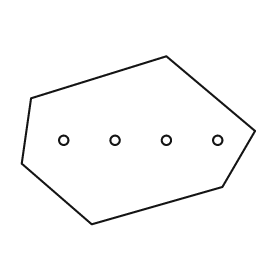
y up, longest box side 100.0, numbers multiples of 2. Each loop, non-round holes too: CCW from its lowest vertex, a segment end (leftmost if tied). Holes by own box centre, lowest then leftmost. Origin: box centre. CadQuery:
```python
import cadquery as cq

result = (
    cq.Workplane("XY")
    .moveTo(-20.0, -36.0)
    .lineTo(36.0, -20.0)
    .lineTo(50.0, 4.0)
    .lineTo(12.0, 36.0)
    .lineTo(-46.0, 18.0)
    .lineTo(-50.0, -10.0)
    .close()
    .moveTo(-32.0, 0.0)
    .circle(2.0)
    .moveTo(-10.0, 0.0)
    .circle(2.0)
    .moveTo(12.0, 0.0)
    .circle(2.0)
    .moveTo(34.0, 0.0)
    .circle(2.0)
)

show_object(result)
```